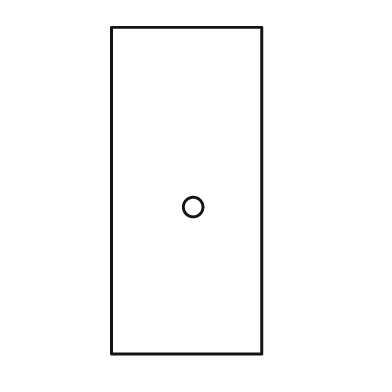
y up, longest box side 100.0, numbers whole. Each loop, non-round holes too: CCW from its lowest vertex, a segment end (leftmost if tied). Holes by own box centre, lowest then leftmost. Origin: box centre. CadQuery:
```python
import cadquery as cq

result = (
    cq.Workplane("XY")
    .moveTo(-23.0, -50.0)
    .lineTo(23.0, -50.0)
    .lineTo(23.0, 50.0)
    .lineTo(-23.0, 50.0)
    .close()
    .moveTo(2.0, -5.0)
    .circle(3.0)
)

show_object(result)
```